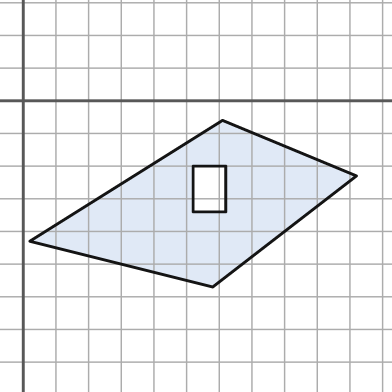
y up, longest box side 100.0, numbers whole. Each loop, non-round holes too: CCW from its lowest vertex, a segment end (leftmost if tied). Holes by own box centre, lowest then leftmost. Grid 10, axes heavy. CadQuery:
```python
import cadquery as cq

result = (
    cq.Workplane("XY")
    .moveTo(58.0, -57.0)
    .lineTo(102.0, -23.0)
    .lineTo(61.0, -6.0)
    .lineTo(2.0, -43.0)
    .close()
    .moveTo(52.0, -34.0)
    .lineTo(62.0, -34.0)
    .lineTo(62.0, -20.0)
    .lineTo(52.0, -20.0)
    .close()
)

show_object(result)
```